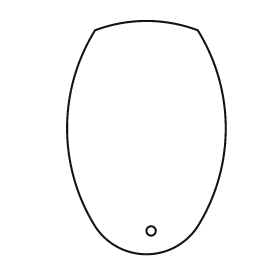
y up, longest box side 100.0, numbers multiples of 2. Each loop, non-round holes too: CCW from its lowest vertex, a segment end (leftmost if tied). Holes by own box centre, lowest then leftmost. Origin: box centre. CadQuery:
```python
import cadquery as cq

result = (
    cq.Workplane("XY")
    .moveTo(-22.0, -38.0)
    .threePointArc((0.0, -50.0), (22.0, -38.0))
    .threePointArc((34.0, 4.0), (22.0, 46.0))
    .threePointArc((0.0, 50.0), (-22.0, 46.0))
    .threePointArc((-34.0, 4.0), (-22.0, -38.0))
    .close()
    .moveTo(2.0, -40.0)
    .circle(2.0)
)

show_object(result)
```